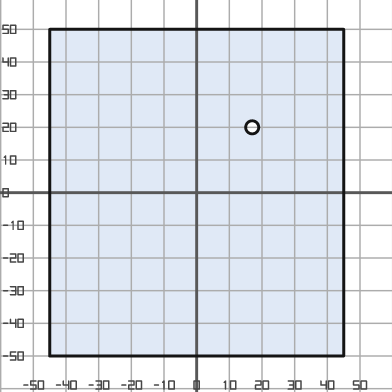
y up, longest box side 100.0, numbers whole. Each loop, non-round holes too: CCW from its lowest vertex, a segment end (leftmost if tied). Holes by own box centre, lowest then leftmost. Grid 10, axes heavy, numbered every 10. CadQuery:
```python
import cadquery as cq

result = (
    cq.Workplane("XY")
    .moveTo(-45.0, -50.0)
    .lineTo(45.0, -50.0)
    .lineTo(45.0, 50.0)
    .lineTo(-45.0, 50.0)
    .close()
    .moveTo(17.0, 20.0)
    .circle(2.0)
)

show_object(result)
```